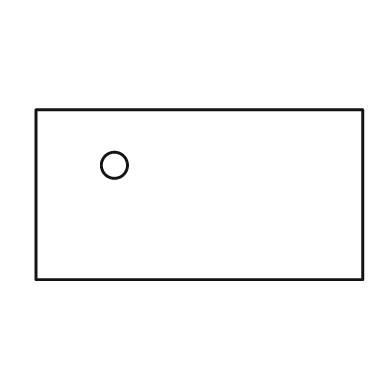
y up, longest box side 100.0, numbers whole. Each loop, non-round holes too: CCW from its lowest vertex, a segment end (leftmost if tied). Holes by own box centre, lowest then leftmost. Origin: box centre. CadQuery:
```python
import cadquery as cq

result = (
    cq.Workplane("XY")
    .moveTo(-50.0, -26.0)
    .lineTo(50.0, -26.0)
    .lineTo(50.0, 26.0)
    .lineTo(-50.0, 26.0)
    .close()
    .moveTo(-26.0, 9.0)
    .circle(4.0)
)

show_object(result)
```